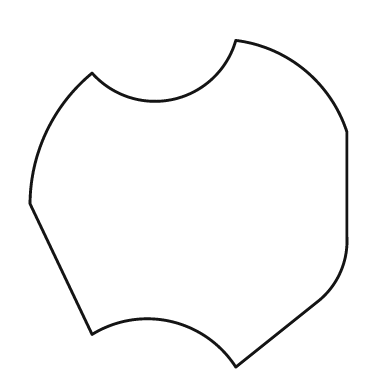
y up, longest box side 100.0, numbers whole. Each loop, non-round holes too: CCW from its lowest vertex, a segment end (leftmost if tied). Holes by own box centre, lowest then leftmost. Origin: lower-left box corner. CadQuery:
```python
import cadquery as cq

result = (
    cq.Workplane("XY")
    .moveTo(63.0, 0.0)
    .lineTo(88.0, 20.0)
    .threePointArc((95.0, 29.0), (97.0, 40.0))
    .lineTo(97.0, 72.0)
    .threePointArc((84.0, 91.0), (63.0, 100.0))
    .threePointArc((44.0, 82.0), (19.0, 90.0))
    .threePointArc((5.0, 72.0), (0.0, 50.0))
    .lineTo(19.0, 10.0)
    .threePointArc((43.0, 14.0), (63.0, 0.0))
    .close()
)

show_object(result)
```